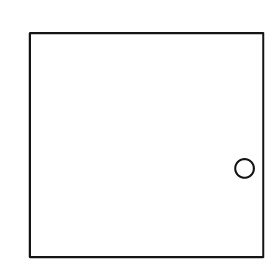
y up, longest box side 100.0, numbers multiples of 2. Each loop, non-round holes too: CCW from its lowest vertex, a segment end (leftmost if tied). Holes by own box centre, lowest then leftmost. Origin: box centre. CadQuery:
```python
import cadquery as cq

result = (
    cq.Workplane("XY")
    .moveTo(-50.0, -48.0)
    .lineTo(50.0, -48.0)
    .lineTo(50.0, 48.0)
    .lineTo(-50.0, 48.0)
    .close()
    .moveTo(42.0, -10.0)
    .circle(4.0)
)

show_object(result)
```